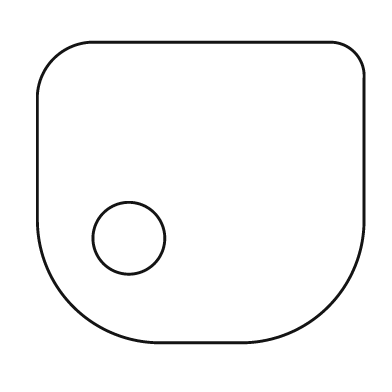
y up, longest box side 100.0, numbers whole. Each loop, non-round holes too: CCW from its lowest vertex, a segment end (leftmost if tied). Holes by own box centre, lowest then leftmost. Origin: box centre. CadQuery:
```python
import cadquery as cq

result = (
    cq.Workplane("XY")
    .moveTo(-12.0, -46.0)
    .lineTo(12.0, -46.0)
    .threePointArc((39.0, -35.0), (50.0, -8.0))
    .lineTo(50.0, 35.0)
    .threePointArc((47.0, 43.0), (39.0, 46.0))
    .lineTo(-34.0, 46.0)
    .threePointArc((-45.0, 41.0), (-50.0, 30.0))
    .lineTo(-50.0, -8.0)
    .threePointArc((-39.0, -35.0), (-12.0, -46.0))
    .close()
    .moveTo(-22.0, -14.0)
    .circle(11.0)
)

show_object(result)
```